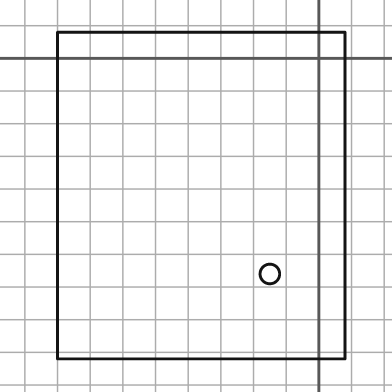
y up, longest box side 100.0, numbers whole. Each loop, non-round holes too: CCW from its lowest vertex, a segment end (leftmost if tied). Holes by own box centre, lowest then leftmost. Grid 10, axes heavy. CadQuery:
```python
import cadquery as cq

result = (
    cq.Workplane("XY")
    .moveTo(-80.0, -92.0)
    .lineTo(8.0, -92.0)
    .lineTo(8.0, 8.0)
    .lineTo(-80.0, 8.0)
    .close()
    .moveTo(-15.0, -66.0)
    .circle(3.0)
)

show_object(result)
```